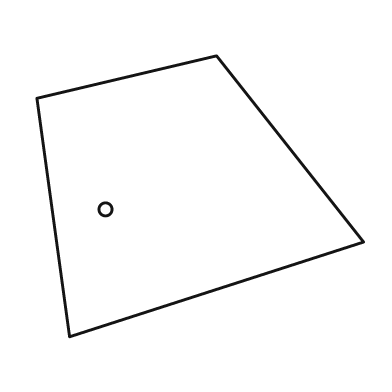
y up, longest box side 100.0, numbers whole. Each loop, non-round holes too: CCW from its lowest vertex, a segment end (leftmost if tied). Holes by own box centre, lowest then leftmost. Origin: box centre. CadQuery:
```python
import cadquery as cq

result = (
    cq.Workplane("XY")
    .moveTo(-40.0, -43.0)
    .lineTo(50.0, -14.0)
    .lineTo(5.0, 43.0)
    .lineTo(-50.0, 30.0)
    .close()
    .moveTo(-29.0, -4.0)
    .circle(2.0)
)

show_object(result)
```